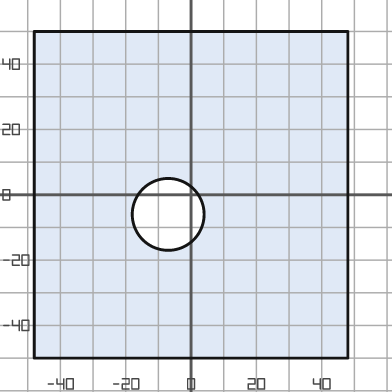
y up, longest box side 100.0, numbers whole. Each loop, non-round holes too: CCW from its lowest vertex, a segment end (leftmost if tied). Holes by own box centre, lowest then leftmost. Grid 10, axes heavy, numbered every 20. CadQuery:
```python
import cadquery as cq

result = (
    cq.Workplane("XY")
    .moveTo(-48.0, -50.0)
    .lineTo(48.0, -50.0)
    .lineTo(48.0, 50.0)
    .lineTo(-48.0, 50.0)
    .close()
    .moveTo(-7.0, -6.0)
    .circle(11.0)
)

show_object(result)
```